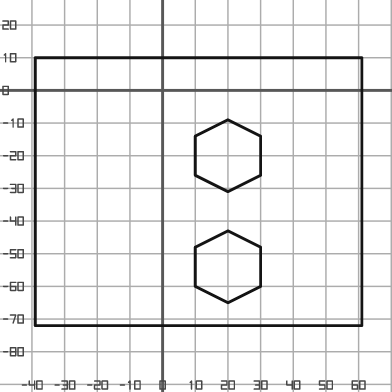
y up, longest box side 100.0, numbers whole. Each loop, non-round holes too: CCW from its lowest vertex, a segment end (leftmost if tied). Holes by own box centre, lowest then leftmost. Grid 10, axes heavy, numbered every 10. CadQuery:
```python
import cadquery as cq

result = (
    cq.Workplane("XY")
    .moveTo(-39.0, -72.0)
    .lineTo(61.0, -72.0)
    .lineTo(61.0, 10.0)
    .lineTo(-39.0, 10.0)
    .close()
    .moveTo(20.0, -65.0)
    .lineTo(30.0, -60.0)
    .lineTo(30.0, -48.0)
    .lineTo(20.0, -43.0)
    .lineTo(10.0, -48.0)
    .lineTo(10.0, -60.0)
    .close()
    .moveTo(20.0, -31.0)
    .lineTo(30.0, -26.0)
    .lineTo(30.0, -14.0)
    .lineTo(20.0, -9.0)
    .lineTo(10.0, -14.0)
    .lineTo(10.0, -26.0)
    .close()
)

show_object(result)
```